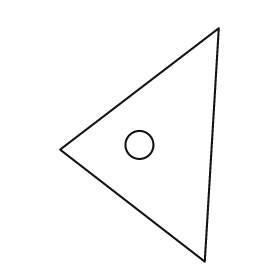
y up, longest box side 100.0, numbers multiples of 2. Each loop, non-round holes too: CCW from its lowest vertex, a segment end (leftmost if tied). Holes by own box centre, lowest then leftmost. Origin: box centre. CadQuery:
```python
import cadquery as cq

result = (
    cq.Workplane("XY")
    .moveTo(28.0, -50.0)
    .lineTo(34.0, 50.0)
    .lineTo(-34.0, -2.0)
    .close()
    .moveTo(0.0, 0.0)
    .circle(6.0)
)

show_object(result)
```